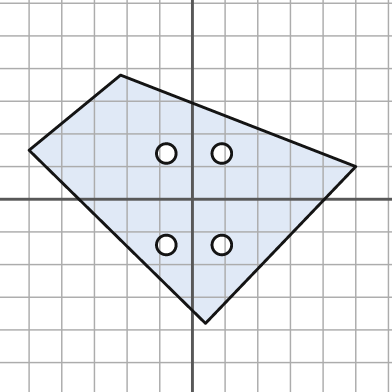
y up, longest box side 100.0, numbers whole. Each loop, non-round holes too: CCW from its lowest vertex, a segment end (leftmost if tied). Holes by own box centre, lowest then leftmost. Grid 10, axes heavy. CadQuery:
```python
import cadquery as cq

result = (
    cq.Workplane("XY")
    .moveTo(4.0, -38.0)
    .lineTo(50.0, 10.0)
    .lineTo(-22.0, 38.0)
    .lineTo(-50.0, 15.0)
    .close()
    .moveTo(-8.0, -14.0)
    .circle(3.0)
    .moveTo(9.0, -14.0)
    .circle(3.0)
    .moveTo(-8.0, 14.0)
    .circle(3.0)
    .moveTo(9.0, 14.0)
    .circle(3.0)
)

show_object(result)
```